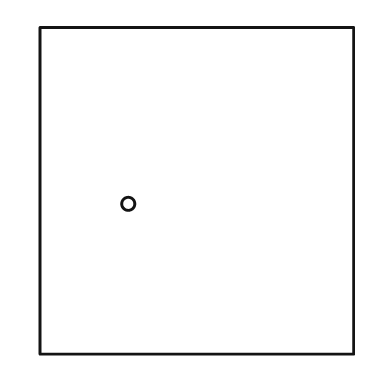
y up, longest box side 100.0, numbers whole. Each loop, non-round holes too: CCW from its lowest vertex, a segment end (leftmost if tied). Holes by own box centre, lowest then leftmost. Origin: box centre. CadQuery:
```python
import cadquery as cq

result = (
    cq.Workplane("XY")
    .moveTo(-48.0, -50.0)
    .lineTo(48.0, -50.0)
    .lineTo(48.0, 50.0)
    .lineTo(-48.0, 50.0)
    .close()
    .moveTo(-21.0, -4.0)
    .circle(2.0)
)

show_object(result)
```